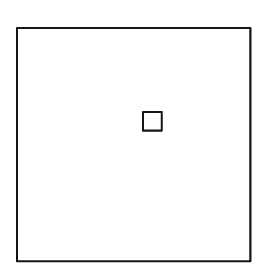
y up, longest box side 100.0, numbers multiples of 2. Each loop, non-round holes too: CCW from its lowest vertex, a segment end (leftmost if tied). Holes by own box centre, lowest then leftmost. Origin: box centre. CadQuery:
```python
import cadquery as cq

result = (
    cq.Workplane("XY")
    .moveTo(-50.0, -50.0)
    .lineTo(50.0, -50.0)
    .lineTo(50.0, 50.0)
    .lineTo(-50.0, 50.0)
    .close()
    .moveTo(4.0, 6.0)
    .lineTo(12.0, 6.0)
    .lineTo(12.0, 14.0)
    .lineTo(4.0, 14.0)
    .close()
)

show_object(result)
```